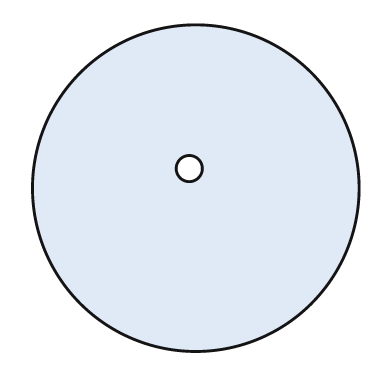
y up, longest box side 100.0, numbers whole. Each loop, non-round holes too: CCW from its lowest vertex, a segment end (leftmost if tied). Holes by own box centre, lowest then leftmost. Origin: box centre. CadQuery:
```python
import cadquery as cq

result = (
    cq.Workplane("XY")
    .moveTo(0.0, 0.0)
    .circle(50.0)
    .moveTo(-2.0, 6.0)
    .circle(4.0)
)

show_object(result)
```